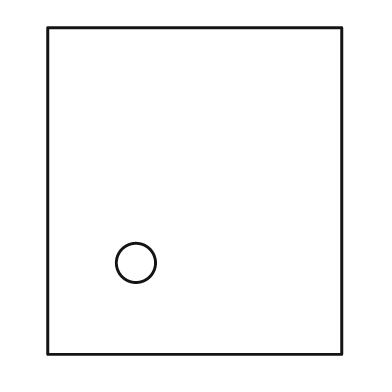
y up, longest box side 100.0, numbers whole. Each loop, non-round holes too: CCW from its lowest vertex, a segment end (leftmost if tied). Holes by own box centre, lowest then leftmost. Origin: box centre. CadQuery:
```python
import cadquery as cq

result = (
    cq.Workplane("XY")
    .moveTo(-45.0, -50.0)
    .lineTo(45.0, -50.0)
    .lineTo(45.0, 50.0)
    .lineTo(-45.0, 50.0)
    .close()
    .moveTo(-18.0, -22.0)
    .circle(6.0)
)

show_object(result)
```